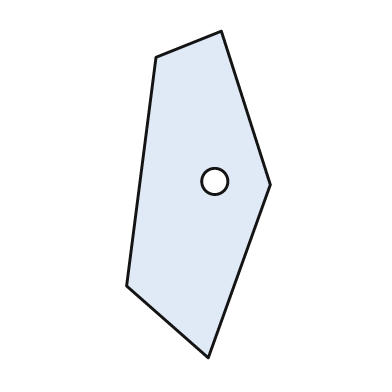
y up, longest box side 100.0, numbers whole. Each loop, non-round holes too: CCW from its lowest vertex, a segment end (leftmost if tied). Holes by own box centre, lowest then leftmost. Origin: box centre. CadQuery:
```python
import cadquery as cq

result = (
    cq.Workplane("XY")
    .moveTo(3.0, -50.0)
    .lineTo(22.0, 3.0)
    .lineTo(7.0, 50.0)
    .lineTo(-13.0, 42.0)
    .lineTo(-22.0, -28.0)
    .close()
    .moveTo(5.0, 4.0)
    .circle(4.0)
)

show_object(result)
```